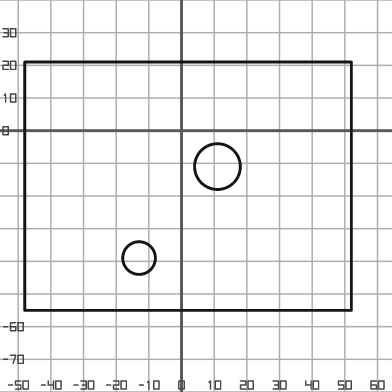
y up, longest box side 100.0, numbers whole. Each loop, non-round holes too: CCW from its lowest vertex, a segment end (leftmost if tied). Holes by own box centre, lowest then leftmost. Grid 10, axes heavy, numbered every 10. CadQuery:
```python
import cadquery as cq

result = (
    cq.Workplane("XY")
    .moveTo(-48.0, -55.0)
    .lineTo(52.0, -55.0)
    .lineTo(52.0, 21.0)
    .lineTo(-48.0, 21.0)
    .close()
    .moveTo(-13.0, -39.0)
    .circle(5.0)
    .moveTo(11.0, -11.0)
    .circle(7.0)
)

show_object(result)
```